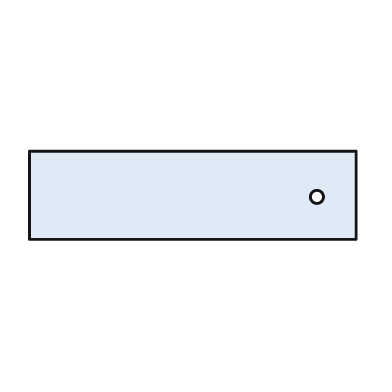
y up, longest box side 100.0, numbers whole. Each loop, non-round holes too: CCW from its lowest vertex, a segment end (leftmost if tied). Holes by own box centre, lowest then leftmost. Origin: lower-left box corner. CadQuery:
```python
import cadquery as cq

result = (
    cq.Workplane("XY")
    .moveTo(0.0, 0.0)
    .lineTo(100.0, 0.0)
    .lineTo(100.0, 27.0)
    .lineTo(0.0, 27.0)
    .close()
    .moveTo(88.0, 13.0)
    .circle(2.0)
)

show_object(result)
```